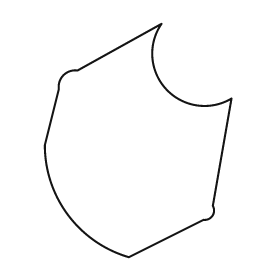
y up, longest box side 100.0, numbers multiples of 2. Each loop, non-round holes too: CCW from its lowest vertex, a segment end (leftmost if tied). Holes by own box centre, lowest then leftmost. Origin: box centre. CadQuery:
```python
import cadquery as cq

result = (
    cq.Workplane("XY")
    .moveTo(-4.0, -50.0)
    .lineTo(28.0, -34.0)
    .threePointArc((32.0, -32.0), (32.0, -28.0))
    .lineTo(40.0, 18.0)
    .threePointArc((12.0, 22.0), (10.0, 50.0))
    .lineTo(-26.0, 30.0)
    .threePointArc((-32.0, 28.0), (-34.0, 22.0))
    .lineTo(-40.0, -2.0)
    .threePointArc((-30.0, -32.0), (-4.0, -50.0))
    .close()
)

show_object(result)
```